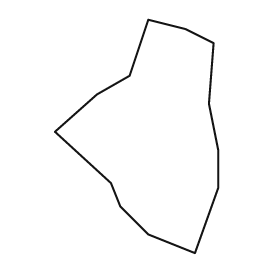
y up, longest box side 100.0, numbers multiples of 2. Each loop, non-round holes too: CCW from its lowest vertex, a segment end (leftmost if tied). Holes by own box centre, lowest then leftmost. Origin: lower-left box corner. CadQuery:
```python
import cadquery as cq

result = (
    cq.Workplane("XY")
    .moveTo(60.0, 0.0)
    .lineTo(70.0, 28.0)
    .lineTo(70.0, 44.0)
    .lineTo(66.0, 64.0)
    .lineTo(68.0, 90.0)
    .lineTo(56.0, 96.0)
    .lineTo(40.0, 100.0)
    .lineTo(32.0, 76.0)
    .lineTo(18.0, 68.0)
    .lineTo(0.0, 52.0)
    .lineTo(24.0, 30.0)
    .lineTo(28.0, 20.0)
    .lineTo(40.0, 8.0)
    .close()
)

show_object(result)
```